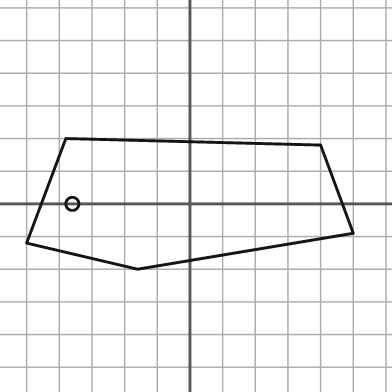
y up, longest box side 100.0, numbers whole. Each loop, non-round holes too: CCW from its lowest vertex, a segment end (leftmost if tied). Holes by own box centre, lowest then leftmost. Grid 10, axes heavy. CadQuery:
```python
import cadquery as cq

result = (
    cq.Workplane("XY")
    .moveTo(-16.0, -20.0)
    .lineTo(50.0, -9.0)
    .lineTo(40.0, 18.0)
    .lineTo(-38.0, 20.0)
    .lineTo(-50.0, -12.0)
    .close()
    .moveTo(-36.0, 0.0)
    .circle(2.0)
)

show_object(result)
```